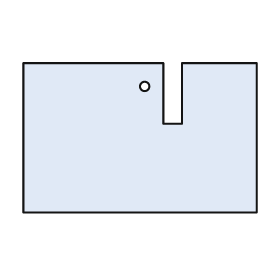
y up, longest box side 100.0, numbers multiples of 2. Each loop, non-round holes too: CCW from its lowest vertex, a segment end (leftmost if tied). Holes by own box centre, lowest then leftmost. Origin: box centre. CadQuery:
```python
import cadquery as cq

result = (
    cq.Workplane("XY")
    .moveTo(-50.0, -32.0)
    .lineTo(50.0, -32.0)
    .lineTo(50.0, 32.0)
    .lineTo(18.0, 32.0)
    .lineTo(18.0, 6.0)
    .lineTo(10.0, 6.0)
    .lineTo(10.0, 32.0)
    .lineTo(-50.0, 32.0)
    .close()
    .moveTo(2.0, 22.0)
    .circle(2.0)
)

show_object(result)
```